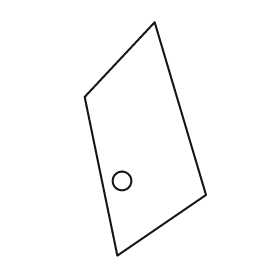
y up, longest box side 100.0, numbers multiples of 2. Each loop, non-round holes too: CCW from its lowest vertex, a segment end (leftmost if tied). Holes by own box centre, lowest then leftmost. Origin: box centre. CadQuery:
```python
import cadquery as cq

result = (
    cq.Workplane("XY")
    .moveTo(-12.0, -50.0)
    .lineTo(26.0, -24.0)
    .lineTo(4.0, 50.0)
    .lineTo(-26.0, 18.0)
    .close()
    .moveTo(-10.0, -18.0)
    .circle(4.0)
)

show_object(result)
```